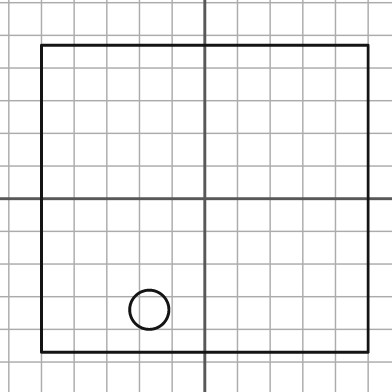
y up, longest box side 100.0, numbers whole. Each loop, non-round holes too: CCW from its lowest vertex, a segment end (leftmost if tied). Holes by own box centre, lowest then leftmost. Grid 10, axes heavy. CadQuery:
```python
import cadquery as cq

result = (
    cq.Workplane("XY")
    .moveTo(-50.0, -47.0)
    .lineTo(50.0, -47.0)
    .lineTo(50.0, 47.0)
    .lineTo(-50.0, 47.0)
    .close()
    .moveTo(-17.0, -34.0)
    .circle(6.0)
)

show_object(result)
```